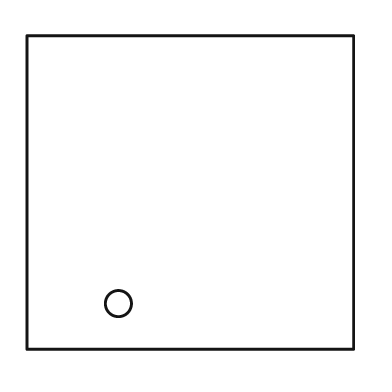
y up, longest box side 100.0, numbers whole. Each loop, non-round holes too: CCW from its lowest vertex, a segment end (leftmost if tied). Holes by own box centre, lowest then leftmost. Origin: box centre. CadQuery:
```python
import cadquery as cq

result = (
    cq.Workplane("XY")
    .moveTo(-50.0, -48.0)
    .lineTo(50.0, -48.0)
    .lineTo(50.0, 48.0)
    .lineTo(-50.0, 48.0)
    .close()
    .moveTo(-22.0, -34.0)
    .circle(4.0)
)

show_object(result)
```